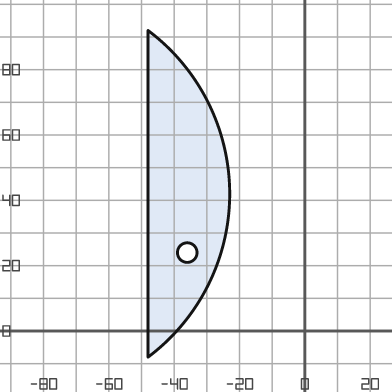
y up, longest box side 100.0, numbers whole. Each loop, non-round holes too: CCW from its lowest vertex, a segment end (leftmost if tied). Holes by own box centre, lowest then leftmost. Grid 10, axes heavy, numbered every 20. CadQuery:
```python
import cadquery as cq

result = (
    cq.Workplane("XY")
    .moveTo(-48.0, -8.0)
    .threePointArc((-23.0, 42.0), (-48.0, 92.0))
    .close()
    .moveTo(-36.0, 24.0)
    .circle(3.0)
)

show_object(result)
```